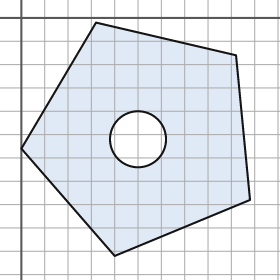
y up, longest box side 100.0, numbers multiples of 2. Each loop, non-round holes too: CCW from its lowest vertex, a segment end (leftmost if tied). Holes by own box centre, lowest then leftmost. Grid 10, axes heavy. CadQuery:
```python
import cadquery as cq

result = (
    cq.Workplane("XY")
    .moveTo(40.0, -102.0)
    .lineTo(98.0, -78.0)
    .lineTo(92.0, -16.0)
    .lineTo(32.0, -2.0)
    .lineTo(0.0, -56.0)
    .close()
    .moveTo(50.0, -52.0)
    .circle(12.0)
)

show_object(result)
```